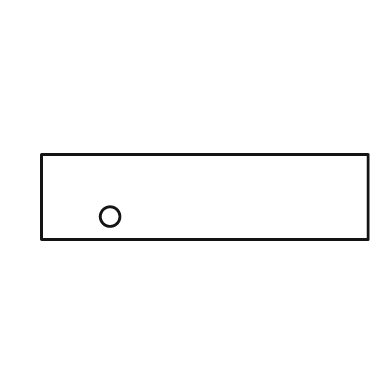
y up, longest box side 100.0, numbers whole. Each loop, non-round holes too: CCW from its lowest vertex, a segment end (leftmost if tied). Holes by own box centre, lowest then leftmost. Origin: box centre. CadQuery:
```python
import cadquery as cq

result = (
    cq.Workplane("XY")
    .moveTo(-50.0, -13.0)
    .lineTo(50.0, -13.0)
    .lineTo(50.0, 13.0)
    .lineTo(-50.0, 13.0)
    .close()
    .moveTo(-29.0, -6.0)
    .circle(3.0)
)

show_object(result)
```